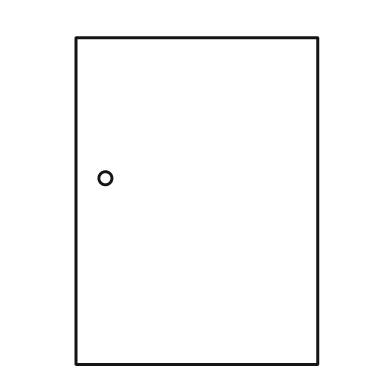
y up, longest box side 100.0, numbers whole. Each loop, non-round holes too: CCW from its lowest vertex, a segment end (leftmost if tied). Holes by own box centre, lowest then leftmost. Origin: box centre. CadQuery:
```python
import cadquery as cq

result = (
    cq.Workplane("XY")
    .moveTo(-37.0, -50.0)
    .lineTo(37.0, -50.0)
    .lineTo(37.0, 50.0)
    .lineTo(-37.0, 50.0)
    .close()
    .moveTo(-28.0, 7.0)
    .circle(2.0)
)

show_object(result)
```